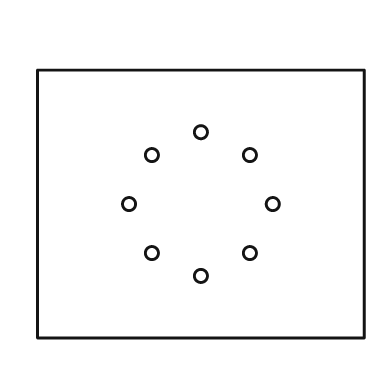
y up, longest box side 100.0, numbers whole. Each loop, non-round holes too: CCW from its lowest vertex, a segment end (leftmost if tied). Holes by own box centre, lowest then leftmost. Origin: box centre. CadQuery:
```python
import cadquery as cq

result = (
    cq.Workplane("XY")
    .moveTo(-50.0, -41.0)
    .lineTo(50.0, -41.0)
    .lineTo(50.0, 41.0)
    .lineTo(-50.0, 41.0)
    .close()
    .moveTo(0.0, -22.0)
    .circle(2.0)
    .moveTo(-15.0, -15.0)
    .circle(2.0)
    .moveTo(15.0, -15.0)
    .circle(2.0)
    .moveTo(-22.0, 0.0)
    .circle(2.0)
    .moveTo(22.0, 0.0)
    .circle(2.0)
    .moveTo(-15.0, 15.0)
    .circle(2.0)
    .moveTo(15.0, 15.0)
    .circle(2.0)
    .moveTo(0.0, 22.0)
    .circle(2.0)
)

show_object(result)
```